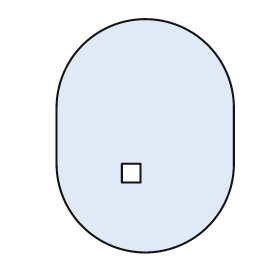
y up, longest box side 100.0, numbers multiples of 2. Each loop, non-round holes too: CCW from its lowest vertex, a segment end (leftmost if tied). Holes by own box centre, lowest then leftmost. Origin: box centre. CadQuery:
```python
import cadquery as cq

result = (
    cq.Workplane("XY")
    .moveTo(-38.0, -12.0)
    .threePointArc((0.0, -50.0), (38.0, -12.0))
    .lineTo(38.0, 12.0)
    .threePointArc((0.0, 50.0), (-38.0, 12.0))
    .close()
    .moveTo(-10.0, -20.0)
    .lineTo(-2.0, -20.0)
    .lineTo(-2.0, -12.0)
    .lineTo(-10.0, -12.0)
    .close()
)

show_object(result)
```